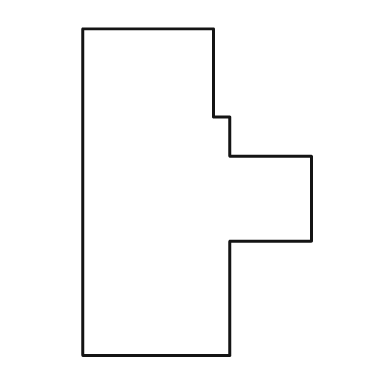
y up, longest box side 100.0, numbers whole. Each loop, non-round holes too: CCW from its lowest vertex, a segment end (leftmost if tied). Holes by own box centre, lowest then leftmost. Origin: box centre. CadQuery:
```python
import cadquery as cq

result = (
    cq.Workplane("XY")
    .moveTo(-35.0, -50.0)
    .lineTo(10.0, -50.0)
    .lineTo(10.0, -15.0)
    .lineTo(35.0, -15.0)
    .lineTo(35.0, 11.0)
    .lineTo(10.0, 11.0)
    .lineTo(10.0, 23.0)
    .lineTo(5.0, 23.0)
    .lineTo(5.0, 50.0)
    .lineTo(-35.0, 50.0)
    .close()
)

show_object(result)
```